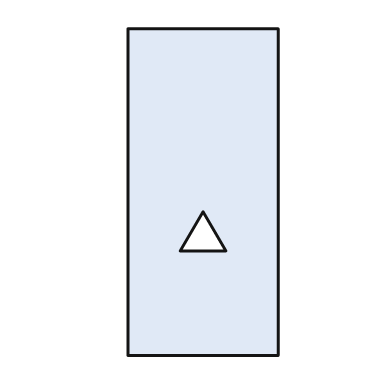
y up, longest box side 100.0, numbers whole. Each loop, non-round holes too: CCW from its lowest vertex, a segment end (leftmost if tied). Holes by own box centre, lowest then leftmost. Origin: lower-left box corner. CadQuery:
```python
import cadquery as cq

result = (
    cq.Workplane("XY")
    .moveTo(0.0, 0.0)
    .lineTo(46.0, 0.0)
    .lineTo(46.0, 100.0)
    .lineTo(0.0, 100.0)
    .close()
    .moveTo(16.0, 32.0)
    .lineTo(30.0, 32.0)
    .lineTo(23.0, 44.0)
    .close()
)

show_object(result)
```